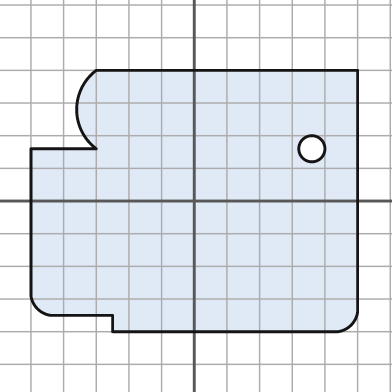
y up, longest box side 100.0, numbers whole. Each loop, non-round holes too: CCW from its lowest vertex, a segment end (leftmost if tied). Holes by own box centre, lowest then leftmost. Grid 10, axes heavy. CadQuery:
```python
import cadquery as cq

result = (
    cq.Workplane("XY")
    .moveTo(-25.0, -40.0)
    .lineTo(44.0, -40.0)
    .threePointArc((48.0, -38.0), (50.0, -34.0))
    .lineTo(50.0, 40.0)
    .lineTo(-30.0, 40.0)
    .threePointArc((-36.0, 28.0), (-30.0, 16.0))
    .lineTo(-50.0, 16.0)
    .lineTo(-50.0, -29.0)
    .threePointArc((-48.0, -33.0), (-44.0, -35.0))
    .lineTo(-25.0, -35.0)
    .close()
    .moveTo(36.0, 16.0)
    .circle(4.0)
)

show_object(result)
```